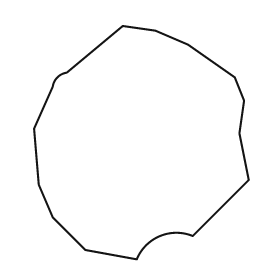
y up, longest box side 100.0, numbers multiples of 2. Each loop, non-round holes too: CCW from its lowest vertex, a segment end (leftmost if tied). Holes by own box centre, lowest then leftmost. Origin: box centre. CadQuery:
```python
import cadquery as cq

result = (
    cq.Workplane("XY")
    .moveTo(-2.0, -50.0)
    .threePointArc((8.0, -40.0), (22.0, -40.0))
    .lineTo(46.0, -16.0)
    .lineTo(42.0, 4.0)
    .lineTo(44.0, 18.0)
    .lineTo(40.0, 28.0)
    .lineTo(20.0, 42.0)
    .lineTo(6.0, 48.0)
    .lineTo(-8.0, 50.0)
    .lineTo(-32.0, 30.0)
    .threePointArc((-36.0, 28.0), (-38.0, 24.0))
    .lineTo(-46.0, 6.0)
    .lineTo(-44.0, -18.0)
    .lineTo(-38.0, -32.0)
    .lineTo(-24.0, -46.0)
    .close()
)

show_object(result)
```